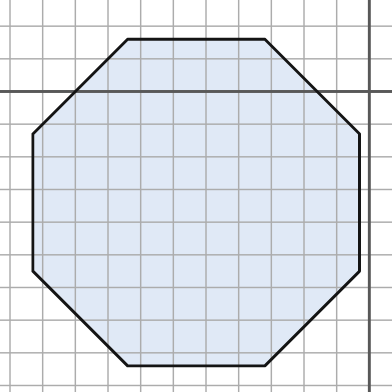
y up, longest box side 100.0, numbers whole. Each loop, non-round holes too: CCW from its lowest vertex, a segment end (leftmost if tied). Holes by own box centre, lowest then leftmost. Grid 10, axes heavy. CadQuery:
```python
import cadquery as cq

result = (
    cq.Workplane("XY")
    .moveTo(-74.0, -84.0)
    .lineTo(-32.0, -84.0)
    .lineTo(-3.0, -55.0)
    .lineTo(-3.0, -13.0)
    .lineTo(-32.0, 16.0)
    .lineTo(-74.0, 16.0)
    .lineTo(-103.0, -13.0)
    .lineTo(-103.0, -55.0)
    .close()
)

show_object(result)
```